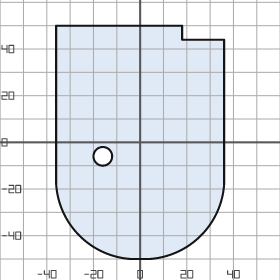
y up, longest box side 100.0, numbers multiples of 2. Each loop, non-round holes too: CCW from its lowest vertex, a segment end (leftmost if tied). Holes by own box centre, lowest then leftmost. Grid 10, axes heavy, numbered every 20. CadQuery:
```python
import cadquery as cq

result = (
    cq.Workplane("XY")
    .moveTo(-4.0, -50.0)
    .lineTo(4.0, -50.0)
    .threePointArc((26.0, -40.0), (36.0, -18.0))
    .lineTo(36.0, 44.0)
    .lineTo(18.0, 44.0)
    .lineTo(18.0, 50.0)
    .lineTo(-36.0, 50.0)
    .lineTo(-36.0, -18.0)
    .threePointArc((-26.0, -40.0), (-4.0, -50.0))
    .close()
    .moveTo(-16.0, -6.0)
    .circle(4.0)
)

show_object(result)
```